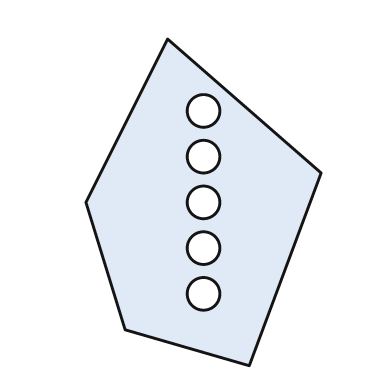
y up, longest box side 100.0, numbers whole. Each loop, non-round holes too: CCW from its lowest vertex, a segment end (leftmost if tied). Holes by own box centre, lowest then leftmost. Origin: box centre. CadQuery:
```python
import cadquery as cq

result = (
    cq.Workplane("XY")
    .moveTo(14.0, -50.0)
    .lineTo(36.0, 9.0)
    .lineTo(-11.0, 50.0)
    .lineTo(-36.0, 0.0)
    .lineTo(-24.0, -39.0)
    .close()
    .moveTo(0.0, -28.0)
    .circle(5.0)
    .moveTo(0.0, -14.0)
    .circle(5.0)
    .moveTo(0.0, 0.0)
    .circle(5.0)
    .moveTo(0.0, 14.0)
    .circle(5.0)
    .moveTo(0.0, 28.0)
    .circle(5.0)
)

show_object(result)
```